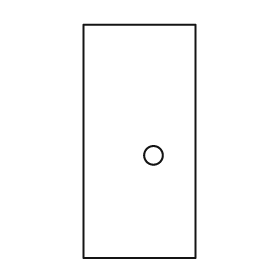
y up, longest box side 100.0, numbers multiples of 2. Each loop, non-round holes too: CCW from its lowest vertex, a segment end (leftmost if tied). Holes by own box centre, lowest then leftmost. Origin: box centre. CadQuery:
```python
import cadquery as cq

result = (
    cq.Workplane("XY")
    .moveTo(-24.0, -50.0)
    .lineTo(24.0, -50.0)
    .lineTo(24.0, 50.0)
    .lineTo(-24.0, 50.0)
    .close()
    .moveTo(6.0, -6.0)
    .circle(4.0)
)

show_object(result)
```